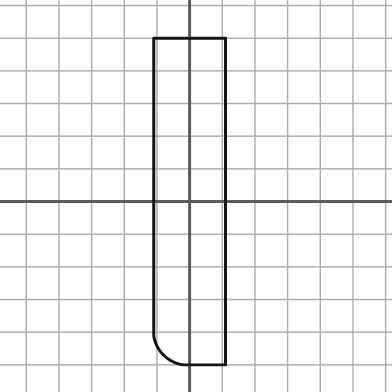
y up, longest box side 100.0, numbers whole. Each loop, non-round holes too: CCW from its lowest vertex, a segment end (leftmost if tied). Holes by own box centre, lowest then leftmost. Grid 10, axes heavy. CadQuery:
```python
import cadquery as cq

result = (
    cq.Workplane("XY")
    .moveTo(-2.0, -50.0)
    .lineTo(11.0, -50.0)
    .lineTo(11.0, 50.0)
    .lineTo(-11.0, 50.0)
    .lineTo(-11.0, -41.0)
    .threePointArc((-8.0, -47.0), (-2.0, -50.0))
    .close()
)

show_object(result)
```